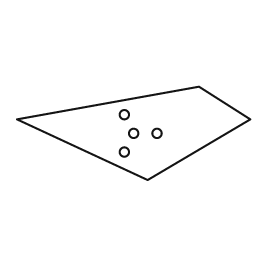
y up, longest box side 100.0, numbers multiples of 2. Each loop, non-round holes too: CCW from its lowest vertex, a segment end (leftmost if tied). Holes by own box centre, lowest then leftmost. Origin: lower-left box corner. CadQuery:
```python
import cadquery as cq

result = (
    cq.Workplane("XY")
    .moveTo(56.0, 0.0)
    .lineTo(100.0, 26.0)
    .lineTo(78.0, 40.0)
    .lineTo(0.0, 26.0)
    .close()
    .moveTo(46.0, 12.0)
    .circle(2.0)
    .moveTo(50.0, 20.0)
    .circle(2.0)
    .moveTo(60.0, 20.0)
    .circle(2.0)
    .moveTo(46.0, 28.0)
    .circle(2.0)
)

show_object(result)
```